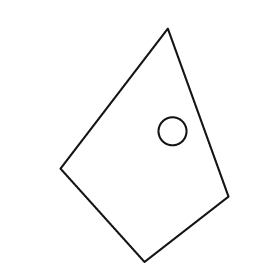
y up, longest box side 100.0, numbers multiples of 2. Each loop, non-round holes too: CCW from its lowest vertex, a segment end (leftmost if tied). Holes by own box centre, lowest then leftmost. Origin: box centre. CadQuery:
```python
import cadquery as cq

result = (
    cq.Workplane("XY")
    .moveTo(0.0, -50.0)
    .lineTo(36.0, -22.0)
    .lineTo(10.0, 50.0)
    .lineTo(-36.0, -10.0)
    .close()
    .moveTo(12.0, 6.0)
    .circle(6.0)
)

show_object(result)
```